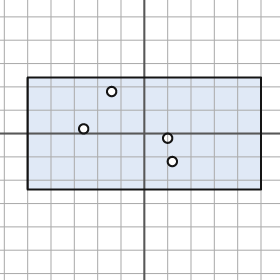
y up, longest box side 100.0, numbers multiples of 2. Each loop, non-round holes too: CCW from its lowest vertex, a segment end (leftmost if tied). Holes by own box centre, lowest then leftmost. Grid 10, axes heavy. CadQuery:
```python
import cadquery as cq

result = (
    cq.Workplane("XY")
    .moveTo(-50.0, -24.0)
    .lineTo(50.0, -24.0)
    .lineTo(50.0, 24.0)
    .lineTo(-50.0, 24.0)
    .close()
    .moveTo(12.0, -12.0)
    .circle(2.0)
    .moveTo(10.0, -2.0)
    .circle(2.0)
    .moveTo(-26.0, 2.0)
    .circle(2.0)
    .moveTo(-14.0, 18.0)
    .circle(2.0)
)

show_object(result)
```